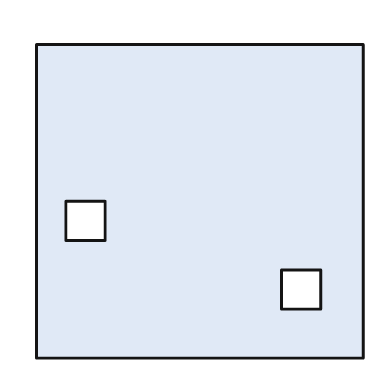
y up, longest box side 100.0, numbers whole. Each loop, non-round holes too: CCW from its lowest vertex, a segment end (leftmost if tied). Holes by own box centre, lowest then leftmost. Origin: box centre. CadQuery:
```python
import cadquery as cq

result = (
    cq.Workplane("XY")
    .moveTo(-50.0, -48.0)
    .lineTo(50.0, -48.0)
    .lineTo(50.0, 48.0)
    .lineTo(-50.0, 48.0)
    .close()
    .moveTo(25.0, -33.0)
    .lineTo(37.0, -33.0)
    .lineTo(37.0, -21.0)
    .lineTo(25.0, -21.0)
    .close()
    .moveTo(-41.0, -12.0)
    .lineTo(-29.0, -12.0)
    .lineTo(-29.0, 0.0)
    .lineTo(-41.0, 0.0)
    .close()
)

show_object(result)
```